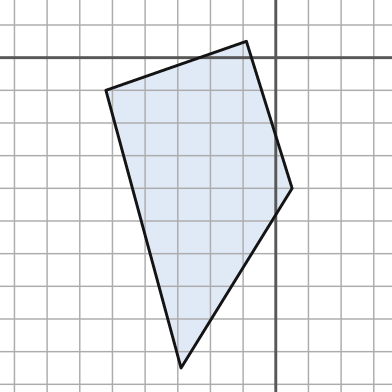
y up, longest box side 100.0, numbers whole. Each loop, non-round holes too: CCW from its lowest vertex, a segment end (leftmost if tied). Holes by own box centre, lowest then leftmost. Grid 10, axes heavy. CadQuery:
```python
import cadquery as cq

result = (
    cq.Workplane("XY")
    .moveTo(-29.0, -95.0)
    .lineTo(5.0, -40.0)
    .lineTo(-9.0, 5.0)
    .lineTo(-52.0, -10.0)
    .close()
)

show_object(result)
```